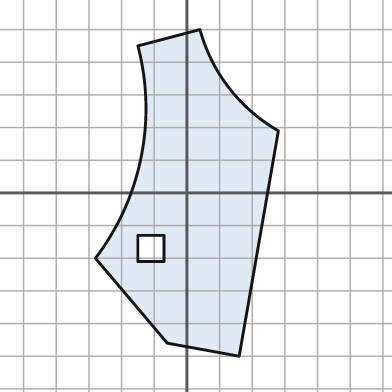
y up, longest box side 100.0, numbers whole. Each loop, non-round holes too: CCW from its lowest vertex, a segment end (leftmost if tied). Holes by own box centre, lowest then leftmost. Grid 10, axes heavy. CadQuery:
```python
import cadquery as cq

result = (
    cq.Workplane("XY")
    .moveTo(16.0, -50.0)
    .lineTo(28.0, 19.0)
    .threePointArc((13.0, 32.0), (4.0, 50.0))
    .lineTo(-15.0, 45.0)
    .threePointArc((-14.0, 11.0), (-28.0, -20.0))
    .lineTo(-6.0, -46.0)
    .close()
    .moveTo(-15.0, -21.0)
    .lineTo(-7.0, -21.0)
    .lineTo(-7.0, -13.0)
    .lineTo(-15.0, -13.0)
    .close()
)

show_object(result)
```